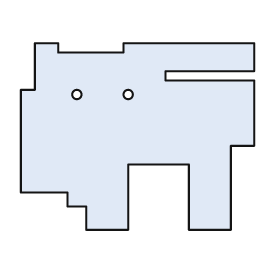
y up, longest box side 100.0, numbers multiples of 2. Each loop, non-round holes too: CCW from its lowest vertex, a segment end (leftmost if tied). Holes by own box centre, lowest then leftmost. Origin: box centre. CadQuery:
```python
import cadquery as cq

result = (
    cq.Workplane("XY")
    .moveTo(-22.0, -40.0)
    .lineTo(-4.0, -40.0)
    .lineTo(-4.0, -12.0)
    .lineTo(22.0, -12.0)
    .lineTo(22.0, -40.0)
    .lineTo(40.0, -40.0)
    .lineTo(40.0, -4.0)
    .lineTo(50.0, -4.0)
    .lineTo(50.0, 24.0)
    .lineTo(12.0, 24.0)
    .lineTo(12.0, 28.0)
    .lineTo(50.0, 28.0)
    .lineTo(50.0, 40.0)
    .lineTo(-6.0, 40.0)
    .lineTo(-6.0, 36.0)
    .lineTo(-34.0, 36.0)
    .lineTo(-34.0, 40.0)
    .lineTo(-44.0, 40.0)
    .lineTo(-44.0, 20.0)
    .lineTo(-50.0, 20.0)
    .lineTo(-50.0, -24.0)
    .lineTo(-30.0, -24.0)
    .lineTo(-30.0, -30.0)
    .lineTo(-22.0, -30.0)
    .close()
    .moveTo(-26.0, 18.0)
    .circle(2.0)
    .moveTo(-4.0, 18.0)
    .circle(2.0)
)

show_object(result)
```